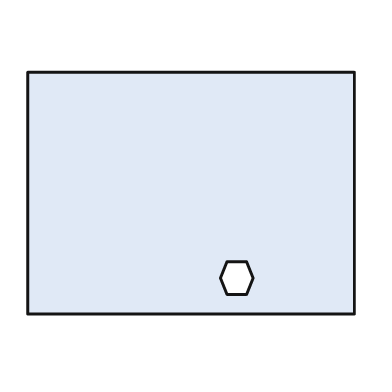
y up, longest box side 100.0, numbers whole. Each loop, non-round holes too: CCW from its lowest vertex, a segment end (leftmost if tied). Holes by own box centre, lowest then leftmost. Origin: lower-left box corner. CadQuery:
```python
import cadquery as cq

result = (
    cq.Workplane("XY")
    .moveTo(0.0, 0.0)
    .lineTo(100.0, 0.0)
    .lineTo(100.0, 74.0)
    .lineTo(0.0, 74.0)
    .close()
    .moveTo(61.0, 6.0)
    .lineTo(67.0, 6.0)
    .lineTo(69.0, 11.0)
    .lineTo(67.0, 16.0)
    .lineTo(61.0, 16.0)
    .lineTo(59.0, 11.0)
    .close()
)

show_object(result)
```